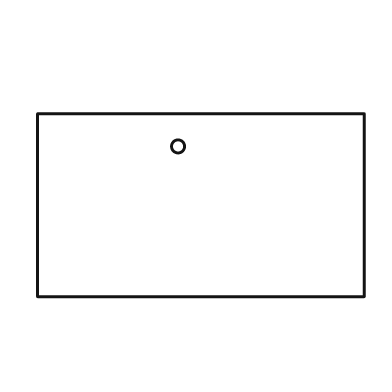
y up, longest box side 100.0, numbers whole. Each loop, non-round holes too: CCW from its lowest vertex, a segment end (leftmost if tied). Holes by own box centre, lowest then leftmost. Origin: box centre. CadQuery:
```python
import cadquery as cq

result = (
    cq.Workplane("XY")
    .moveTo(-50.0, -28.0)
    .lineTo(50.0, -28.0)
    .lineTo(50.0, 28.0)
    .lineTo(-50.0, 28.0)
    .close()
    .moveTo(-7.0, 18.0)
    .circle(2.0)
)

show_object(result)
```